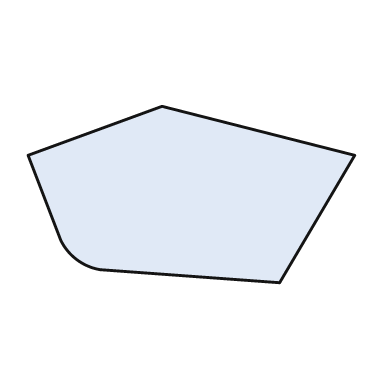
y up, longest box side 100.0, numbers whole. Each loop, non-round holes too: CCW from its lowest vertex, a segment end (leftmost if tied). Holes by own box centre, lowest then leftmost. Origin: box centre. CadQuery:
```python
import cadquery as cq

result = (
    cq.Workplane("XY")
    .moveTo(27.0, -27.0)
    .lineTo(50.0, 12.0)
    .lineTo(-9.0, 27.0)
    .lineTo(-50.0, 12.0)
    .lineTo(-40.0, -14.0)
    .threePointArc((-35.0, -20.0), (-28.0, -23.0))
    .close()
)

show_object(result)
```